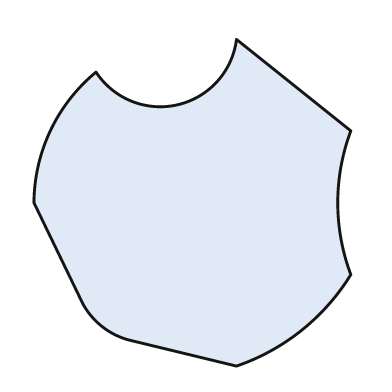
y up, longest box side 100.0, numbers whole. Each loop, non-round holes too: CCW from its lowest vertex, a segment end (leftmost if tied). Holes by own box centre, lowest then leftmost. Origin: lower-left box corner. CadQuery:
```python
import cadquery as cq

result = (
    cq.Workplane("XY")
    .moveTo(62.0, 0.0)
    .threePointArc((82.0, 11.0), (97.0, 28.0))
    .threePointArc((93.0, 50.0), (97.0, 72.0))
    .lineTo(62.0, 100.0)
    .threePointArc((44.0, 80.0), (19.0, 90.0))
    .threePointArc((5.0, 72.0), (0.0, 50.0))
    .lineTo(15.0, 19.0)
    .threePointArc((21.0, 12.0), (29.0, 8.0))
    .close()
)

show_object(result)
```